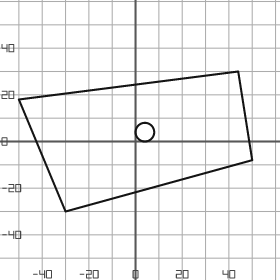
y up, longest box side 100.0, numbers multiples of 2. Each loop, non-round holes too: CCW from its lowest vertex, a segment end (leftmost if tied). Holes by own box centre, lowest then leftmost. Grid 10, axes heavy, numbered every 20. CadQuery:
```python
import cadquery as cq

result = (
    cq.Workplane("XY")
    .moveTo(-30.0, -30.0)
    .lineTo(50.0, -8.0)
    .lineTo(44.0, 30.0)
    .lineTo(-50.0, 18.0)
    .close()
    .moveTo(4.0, 4.0)
    .circle(4.0)
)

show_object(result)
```